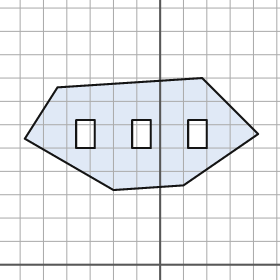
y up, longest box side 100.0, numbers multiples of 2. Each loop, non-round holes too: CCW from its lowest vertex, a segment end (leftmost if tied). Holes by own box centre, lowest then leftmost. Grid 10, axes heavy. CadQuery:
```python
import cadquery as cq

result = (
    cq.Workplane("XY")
    .moveTo(-20.0, 32.0)
    .lineTo(10.0, 34.0)
    .lineTo(42.0, 56.0)
    .lineTo(18.0, 80.0)
    .lineTo(-44.0, 76.0)
    .lineTo(-58.0, 54.0)
    .close()
    .moveTo(-36.0, 50.0)
    .lineTo(-28.0, 50.0)
    .lineTo(-28.0, 62.0)
    .lineTo(-36.0, 62.0)
    .close()
    .moveTo(-12.0, 50.0)
    .lineTo(-4.0, 50.0)
    .lineTo(-4.0, 62.0)
    .lineTo(-12.0, 62.0)
    .close()
    .moveTo(12.0, 50.0)
    .lineTo(20.0, 50.0)
    .lineTo(20.0, 62.0)
    .lineTo(12.0, 62.0)
    .close()
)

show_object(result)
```